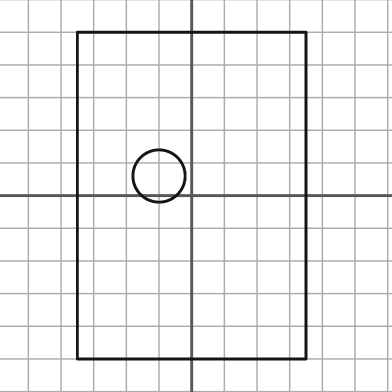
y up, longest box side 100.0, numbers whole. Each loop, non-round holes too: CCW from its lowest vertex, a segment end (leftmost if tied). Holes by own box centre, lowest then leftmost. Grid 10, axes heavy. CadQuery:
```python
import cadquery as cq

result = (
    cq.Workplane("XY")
    .moveTo(-35.0, -50.0)
    .lineTo(35.0, -50.0)
    .lineTo(35.0, 50.0)
    .lineTo(-35.0, 50.0)
    .close()
    .moveTo(-10.0, 6.0)
    .circle(8.0)
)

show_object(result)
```